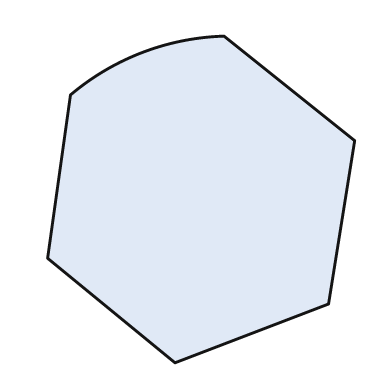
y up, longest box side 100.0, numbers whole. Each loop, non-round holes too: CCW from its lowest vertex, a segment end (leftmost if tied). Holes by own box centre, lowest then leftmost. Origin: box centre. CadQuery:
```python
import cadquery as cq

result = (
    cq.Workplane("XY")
    .moveTo(-8.0, -50.0)
    .lineTo(39.0, -32.0)
    .lineTo(47.0, 18.0)
    .lineTo(7.0, 50.0)
    .threePointArc((-18.0, 45.0), (-40.0, 32.0))
    .lineTo(-47.0, -18.0)
    .close()
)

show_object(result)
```